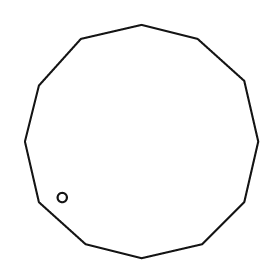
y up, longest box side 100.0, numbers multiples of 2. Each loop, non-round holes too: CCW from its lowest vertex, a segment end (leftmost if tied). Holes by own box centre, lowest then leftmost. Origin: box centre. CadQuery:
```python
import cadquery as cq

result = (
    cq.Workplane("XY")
    .moveTo(0.0, -50.0)
    .lineTo(26.0, -44.0)
    .lineTo(44.0, -26.0)
    .lineTo(50.0, 0.0)
    .lineTo(44.0, 26.0)
    .lineTo(24.0, 44.0)
    .lineTo(0.0, 50.0)
    .lineTo(-26.0, 44.0)
    .lineTo(-44.0, 24.0)
    .lineTo(-50.0, 0.0)
    .lineTo(-44.0, -26.0)
    .lineTo(-24.0, -44.0)
    .close()
    .moveTo(-34.0, -24.0)
    .circle(2.0)
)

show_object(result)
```